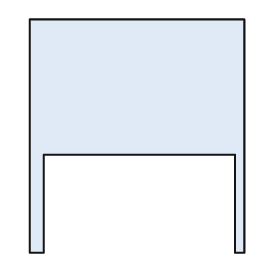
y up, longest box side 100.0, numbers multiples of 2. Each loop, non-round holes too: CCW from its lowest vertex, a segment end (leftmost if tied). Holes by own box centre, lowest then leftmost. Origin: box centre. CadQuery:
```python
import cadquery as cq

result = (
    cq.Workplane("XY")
    .moveTo(-46.0, -50.0)
    .lineTo(-40.0, -50.0)
    .lineTo(-40.0, -8.0)
    .lineTo(42.0, -8.0)
    .lineTo(42.0, -50.0)
    .lineTo(46.0, -50.0)
    .lineTo(46.0, 50.0)
    .lineTo(-46.0, 50.0)
    .close()
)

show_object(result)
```